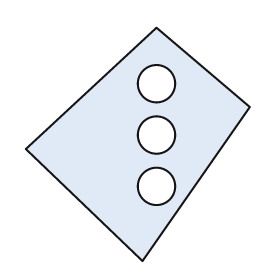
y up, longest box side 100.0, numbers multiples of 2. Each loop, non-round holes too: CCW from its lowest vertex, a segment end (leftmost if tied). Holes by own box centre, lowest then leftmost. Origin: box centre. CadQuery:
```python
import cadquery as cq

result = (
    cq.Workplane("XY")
    .moveTo(2.0, -50.0)
    .lineTo(48.0, 16.0)
    .lineTo(8.0, 50.0)
    .lineTo(-48.0, -2.0)
    .close()
    .moveTo(8.0, -18.0)
    .circle(8.0)
    .moveTo(8.0, 4.0)
    .circle(8.0)
    .moveTo(8.0, 26.0)
    .circle(8.0)
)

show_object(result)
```